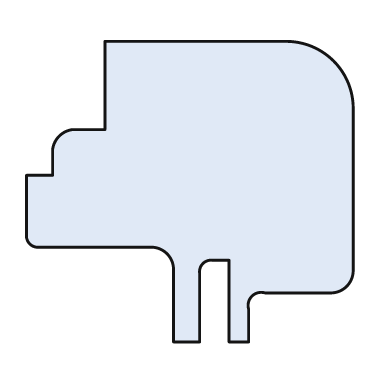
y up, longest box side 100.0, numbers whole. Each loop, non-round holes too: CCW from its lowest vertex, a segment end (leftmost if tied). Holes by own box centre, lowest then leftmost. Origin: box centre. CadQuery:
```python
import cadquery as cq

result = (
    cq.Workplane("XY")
    .moveTo(-5.0, -46.0)
    .lineTo(3.0, -46.0)
    .lineTo(3.0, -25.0)
    .threePointArc((4.0, -22.0), (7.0, -21.0))
    .lineTo(12.0, -21.0)
    .lineTo(12.0, -46.0)
    .lineTo(18.0, -46.0)
    .lineTo(18.0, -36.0)
    .threePointArc((19.0, -32.0), (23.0, -31.0))
    .lineTo(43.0, -31.0)
    .threePointArc((48.0, -29.0), (50.0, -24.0))
    .lineTo(50.0, 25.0)
    .threePointArc((44.0, 40.0), (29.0, 46.0))
    .lineTo(-26.0, 46.0)
    .lineTo(-26.0, 19.0)
    .lineTo(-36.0, 19.0)
    .threePointArc((-40.0, 17.0), (-42.0, 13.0))
    .lineTo(-42.0, 5.0)
    .lineTo(-50.0, 5.0)
    .lineTo(-50.0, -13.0)
    .threePointArc((-49.0, -16.0), (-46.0, -17.0))
    .lineTo(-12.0, -17.0)
    .threePointArc((-7.0, -19.0), (-5.0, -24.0))
    .close()
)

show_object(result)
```